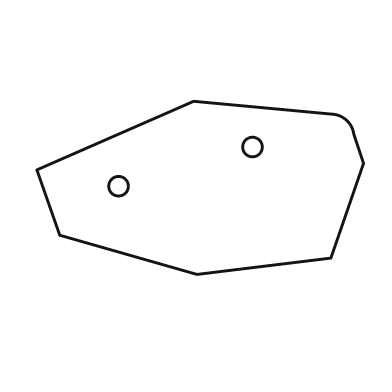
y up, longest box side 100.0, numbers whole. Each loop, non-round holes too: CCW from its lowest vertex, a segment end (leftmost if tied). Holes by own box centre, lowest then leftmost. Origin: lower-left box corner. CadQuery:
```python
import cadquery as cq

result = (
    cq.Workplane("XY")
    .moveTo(49.0, 0.0)
    .lineTo(90.0, 5.0)
    .lineTo(100.0, 34.0)
    .lineTo(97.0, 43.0)
    .threePointArc((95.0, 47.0), (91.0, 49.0))
    .lineTo(48.0, 53.0)
    .lineTo(0.0, 32.0)
    .lineTo(7.0, 12.0)
    .close()
    .moveTo(25.0, 27.0)
    .circle(3.0)
    .moveTo(66.0, 39.0)
    .circle(3.0)
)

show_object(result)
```